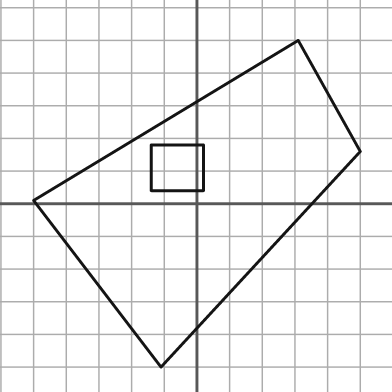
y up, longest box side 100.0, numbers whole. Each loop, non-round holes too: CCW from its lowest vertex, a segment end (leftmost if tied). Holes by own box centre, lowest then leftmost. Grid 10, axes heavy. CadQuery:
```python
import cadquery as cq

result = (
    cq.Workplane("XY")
    .moveTo(-11.0, -50.0)
    .lineTo(50.0, 16.0)
    .lineTo(31.0, 50.0)
    .lineTo(-50.0, 1.0)
    .close()
    .moveTo(-14.0, 4.0)
    .lineTo(2.0, 4.0)
    .lineTo(2.0, 18.0)
    .lineTo(-14.0, 18.0)
    .close()
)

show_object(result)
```